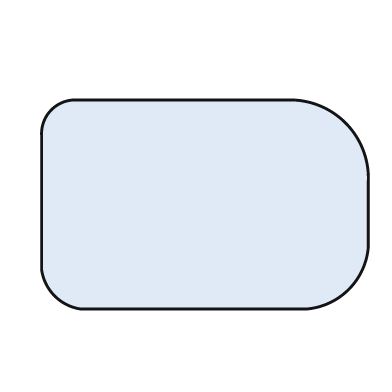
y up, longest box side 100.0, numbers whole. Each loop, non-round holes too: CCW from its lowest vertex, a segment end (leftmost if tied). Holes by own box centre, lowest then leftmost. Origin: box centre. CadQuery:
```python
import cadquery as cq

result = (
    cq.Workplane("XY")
    .moveTo(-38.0, -32.0)
    .lineTo(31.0, -32.0)
    .threePointArc((44.0, -26.0), (50.0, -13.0))
    .lineTo(50.0, 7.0)
    .threePointArc((43.0, 25.0), (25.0, 32.0))
    .lineTo(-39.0, 32.0)
    .threePointArc((-47.0, 29.0), (-50.0, 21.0))
    .lineTo(-50.0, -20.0)
    .threePointArc((-46.0, -28.0), (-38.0, -32.0))
    .close()
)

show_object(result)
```